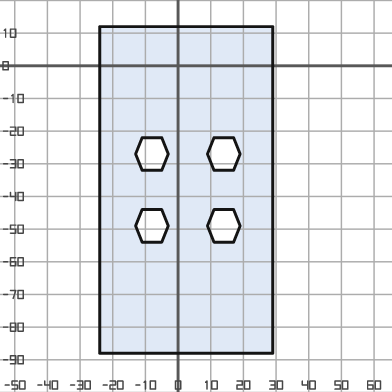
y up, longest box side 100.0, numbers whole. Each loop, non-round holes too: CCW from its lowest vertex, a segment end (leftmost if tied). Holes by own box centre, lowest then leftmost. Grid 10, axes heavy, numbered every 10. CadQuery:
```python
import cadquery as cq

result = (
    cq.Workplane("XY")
    .moveTo(-24.0, -88.0)
    .lineTo(29.0, -88.0)
    .lineTo(29.0, 12.0)
    .lineTo(-24.0, 12.0)
    .close()
    .moveTo(-11.0, -54.0)
    .lineTo(-5.0, -54.0)
    .lineTo(-3.0, -49.0)
    .lineTo(-5.0, -44.0)
    .lineTo(-11.0, -44.0)
    .lineTo(-13.0, -49.0)
    .close()
    .moveTo(11.0, -54.0)
    .lineTo(17.0, -54.0)
    .lineTo(19.0, -49.0)
    .lineTo(17.0, -44.0)
    .lineTo(11.0, -44.0)
    .lineTo(9.0, -49.0)
    .close()
    .moveTo(-11.0, -32.0)
    .lineTo(-5.0, -32.0)
    .lineTo(-3.0, -27.0)
    .lineTo(-5.0, -22.0)
    .lineTo(-11.0, -22.0)
    .lineTo(-13.0, -27.0)
    .close()
    .moveTo(11.0, -32.0)
    .lineTo(17.0, -32.0)
    .lineTo(19.0, -27.0)
    .lineTo(17.0, -22.0)
    .lineTo(11.0, -22.0)
    .lineTo(9.0, -27.0)
    .close()
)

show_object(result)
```